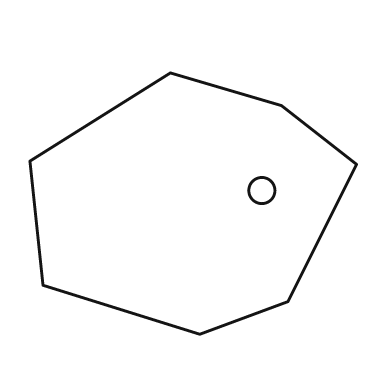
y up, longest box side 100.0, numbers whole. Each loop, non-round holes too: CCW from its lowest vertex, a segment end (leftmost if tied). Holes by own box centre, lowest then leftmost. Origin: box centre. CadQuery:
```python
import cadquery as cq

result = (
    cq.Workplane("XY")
    .moveTo(2.0, -40.0)
    .lineTo(29.0, -30.0)
    .lineTo(50.0, 12.0)
    .lineTo(27.0, 30.0)
    .lineTo(-7.0, 40.0)
    .lineTo(-50.0, 13.0)
    .lineTo(-46.0, -25.0)
    .close()
    .moveTo(21.0, 4.0)
    .circle(4.0)
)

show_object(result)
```